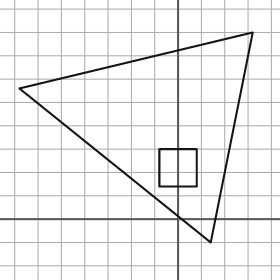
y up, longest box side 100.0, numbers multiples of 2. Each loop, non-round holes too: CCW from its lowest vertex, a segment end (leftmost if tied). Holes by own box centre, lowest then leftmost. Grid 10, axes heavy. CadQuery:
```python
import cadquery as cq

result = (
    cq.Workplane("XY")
    .moveTo(14.0, -10.0)
    .lineTo(32.0, 80.0)
    .lineTo(-68.0, 56.0)
    .close()
    .moveTo(-8.0, 14.0)
    .lineTo(8.0, 14.0)
    .lineTo(8.0, 30.0)
    .lineTo(-8.0, 30.0)
    .close()
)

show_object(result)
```